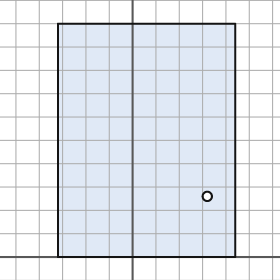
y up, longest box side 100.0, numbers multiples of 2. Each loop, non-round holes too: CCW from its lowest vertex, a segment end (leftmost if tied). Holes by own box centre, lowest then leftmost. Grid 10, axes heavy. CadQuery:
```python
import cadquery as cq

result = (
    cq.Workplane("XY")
    .moveTo(-32.0, 0.0)
    .lineTo(44.0, 0.0)
    .lineTo(44.0, 100.0)
    .lineTo(-32.0, 100.0)
    .close()
    .moveTo(32.0, 26.0)
    .circle(2.0)
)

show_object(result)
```